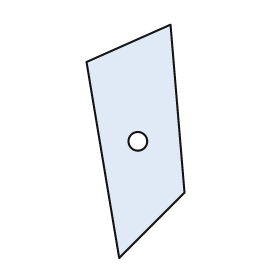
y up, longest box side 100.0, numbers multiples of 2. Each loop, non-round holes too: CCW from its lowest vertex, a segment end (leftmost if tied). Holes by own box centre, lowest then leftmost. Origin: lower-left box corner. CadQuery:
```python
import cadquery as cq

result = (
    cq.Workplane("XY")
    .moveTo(14.0, 0.0)
    .lineTo(42.0, 28.0)
    .lineTo(36.0, 100.0)
    .lineTo(0.0, 84.0)
    .close()
    .moveTo(22.0, 50.0)
    .circle(4.0)
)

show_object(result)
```